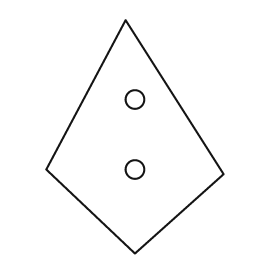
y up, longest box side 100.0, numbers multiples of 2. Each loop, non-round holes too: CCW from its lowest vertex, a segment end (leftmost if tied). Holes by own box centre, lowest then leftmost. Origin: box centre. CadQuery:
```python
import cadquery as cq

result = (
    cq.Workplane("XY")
    .moveTo(0.0, -50.0)
    .lineTo(38.0, -16.0)
    .lineTo(-4.0, 50.0)
    .lineTo(-38.0, -14.0)
    .close()
    .moveTo(0.0, -14.0)
    .circle(4.0)
    .moveTo(0.0, 16.0)
    .circle(4.0)
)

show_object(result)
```